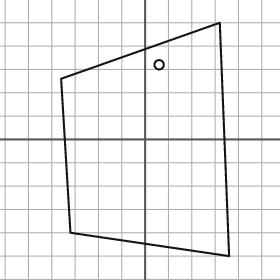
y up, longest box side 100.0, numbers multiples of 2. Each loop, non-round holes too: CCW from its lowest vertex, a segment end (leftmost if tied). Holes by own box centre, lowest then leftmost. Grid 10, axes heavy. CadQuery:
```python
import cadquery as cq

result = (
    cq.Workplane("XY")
    .moveTo(36.0, -50.0)
    .lineTo(32.0, 50.0)
    .lineTo(-36.0, 26.0)
    .lineTo(-32.0, -40.0)
    .close()
    .moveTo(6.0, 32.0)
    .circle(2.0)
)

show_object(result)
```